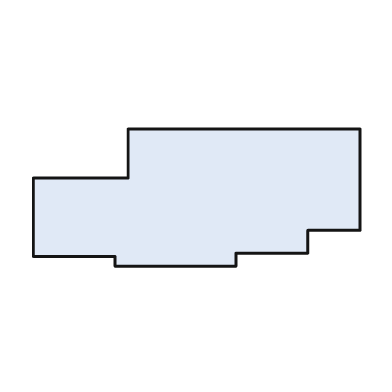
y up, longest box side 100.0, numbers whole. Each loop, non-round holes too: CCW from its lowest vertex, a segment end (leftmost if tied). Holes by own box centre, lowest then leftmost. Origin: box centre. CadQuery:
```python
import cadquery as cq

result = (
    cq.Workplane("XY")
    .moveTo(-25.0, -21.0)
    .lineTo(12.0, -21.0)
    .lineTo(12.0, -17.0)
    .lineTo(34.0, -17.0)
    .lineTo(34.0, -10.0)
    .lineTo(50.0, -10.0)
    .lineTo(50.0, 21.0)
    .lineTo(-21.0, 21.0)
    .lineTo(-21.0, 6.0)
    .lineTo(-50.0, 6.0)
    .lineTo(-50.0, -18.0)
    .lineTo(-25.0, -18.0)
    .close()
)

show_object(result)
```